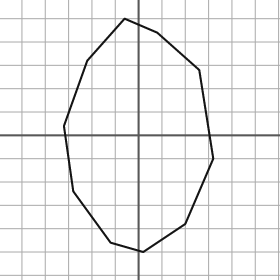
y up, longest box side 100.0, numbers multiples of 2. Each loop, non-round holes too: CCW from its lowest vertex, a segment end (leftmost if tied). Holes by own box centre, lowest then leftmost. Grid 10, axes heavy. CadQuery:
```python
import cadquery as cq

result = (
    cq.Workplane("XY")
    .moveTo(2.0, -50.0)
    .lineTo(20.0, -38.0)
    .lineTo(32.0, -10.0)
    .lineTo(26.0, 28.0)
    .lineTo(8.0, 44.0)
    .lineTo(-6.0, 50.0)
    .lineTo(-22.0, 32.0)
    .lineTo(-32.0, 4.0)
    .lineTo(-28.0, -24.0)
    .lineTo(-12.0, -46.0)
    .close()
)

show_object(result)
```